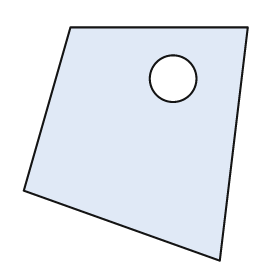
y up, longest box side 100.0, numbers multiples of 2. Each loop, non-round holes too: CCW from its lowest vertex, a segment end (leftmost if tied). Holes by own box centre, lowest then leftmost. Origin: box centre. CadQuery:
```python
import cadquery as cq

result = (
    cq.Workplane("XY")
    .moveTo(36.0, -50.0)
    .lineTo(48.0, 50.0)
    .lineTo(-28.0, 50.0)
    .lineTo(-48.0, -20.0)
    .close()
    .moveTo(16.0, 28.0)
    .circle(10.0)
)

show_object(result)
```